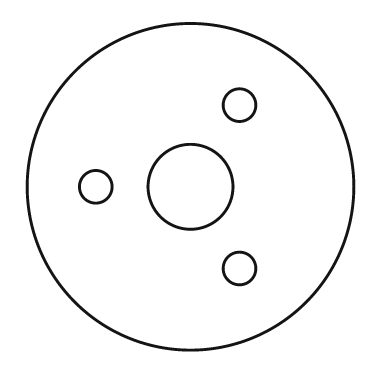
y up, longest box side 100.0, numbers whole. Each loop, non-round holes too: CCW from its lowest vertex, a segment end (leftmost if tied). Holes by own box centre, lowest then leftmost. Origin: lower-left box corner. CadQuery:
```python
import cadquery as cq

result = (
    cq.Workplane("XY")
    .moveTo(50.0, 50.0)
    .circle(50.0)
    .moveTo(65.0, 25.0)
    .circle(5.0)
    .moveTo(21.0, 50.0)
    .circle(5.0)
    .moveTo(50.0, 50.0)
    .circle(13.0)
    .moveTo(65.0, 75.0)
    .circle(5.0)
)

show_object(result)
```